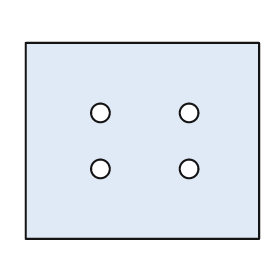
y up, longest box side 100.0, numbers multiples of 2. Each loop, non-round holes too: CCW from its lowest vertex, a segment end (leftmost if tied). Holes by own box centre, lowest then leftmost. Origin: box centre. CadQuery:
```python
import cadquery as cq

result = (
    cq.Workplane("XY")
    .moveTo(-50.0, -42.0)
    .lineTo(50.0, -42.0)
    .lineTo(50.0, 42.0)
    .lineTo(-50.0, 42.0)
    .close()
    .moveTo(-18.0, -12.0)
    .circle(4.0)
    .moveTo(20.0, -12.0)
    .circle(4.0)
    .moveTo(-18.0, 12.0)
    .circle(4.0)
    .moveTo(20.0, 12.0)
    .circle(4.0)
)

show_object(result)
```